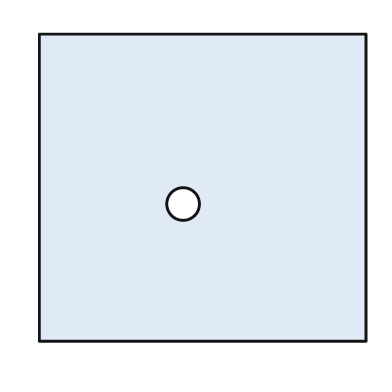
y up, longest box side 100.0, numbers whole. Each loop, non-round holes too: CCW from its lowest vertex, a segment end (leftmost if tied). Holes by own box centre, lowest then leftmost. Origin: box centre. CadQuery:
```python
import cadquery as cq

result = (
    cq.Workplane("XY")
    .moveTo(-50.0, -47.0)
    .lineTo(50.0, -47.0)
    .lineTo(50.0, 47.0)
    .lineTo(-50.0, 47.0)
    .close()
    .moveTo(-6.0, -5.0)
    .circle(5.0)
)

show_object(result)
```